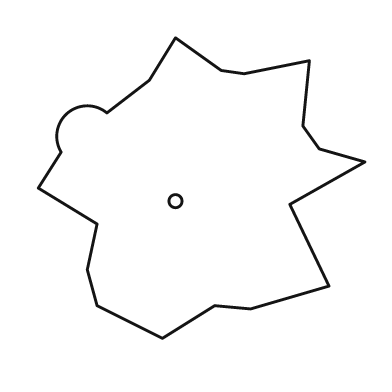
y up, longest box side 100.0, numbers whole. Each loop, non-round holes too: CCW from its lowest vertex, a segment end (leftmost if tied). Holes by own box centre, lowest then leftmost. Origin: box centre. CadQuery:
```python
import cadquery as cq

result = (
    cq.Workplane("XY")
    .moveTo(-12.0, -46.0)
    .lineTo(4.0, -36.0)
    .lineTo(15.0, -37.0)
    .lineTo(39.0, -30.0)
    .lineTo(27.0, -5.0)
    .lineTo(50.0, 8.0)
    .lineTo(36.0, 12.0)
    .lineTo(31.0, 19.0)
    .lineTo(33.0, 39.0)
    .lineTo(13.0, 35.0)
    .lineTo(6.0, 36.0)
    .lineTo(-8.0, 46.0)
    .lineTo(-16.0, 33.0)
    .lineTo(-29.0, 23.0)
    .threePointArc((-41.0, 23.0), (-43.0, 11.0))
    .lineTo(-50.0, 0.0)
    .lineTo(-32.0, -11.0)
    .lineTo(-35.0, -25.0)
    .lineTo(-32.0, -36.0)
    .close()
    .moveTo(-8.0, -4.0)
    .circle(2.0)
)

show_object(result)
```